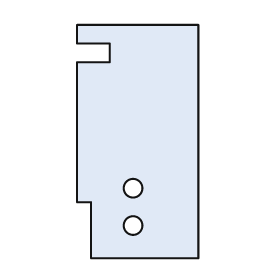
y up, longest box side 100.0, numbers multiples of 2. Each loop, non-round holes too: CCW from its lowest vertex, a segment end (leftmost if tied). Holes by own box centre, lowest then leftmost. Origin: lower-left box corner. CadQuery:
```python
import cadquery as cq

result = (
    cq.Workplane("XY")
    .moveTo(6.0, 0.0)
    .lineTo(52.0, 0.0)
    .lineTo(52.0, 100.0)
    .lineTo(0.0, 100.0)
    .lineTo(0.0, 92.0)
    .lineTo(14.0, 92.0)
    .lineTo(14.0, 84.0)
    .lineTo(0.0, 84.0)
    .lineTo(0.0, 24.0)
    .lineTo(6.0, 24.0)
    .close()
    .moveTo(24.0, 14.0)
    .circle(4.0)
    .moveTo(24.0, 30.0)
    .circle(4.0)
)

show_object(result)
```